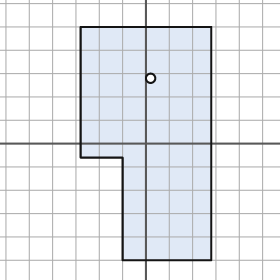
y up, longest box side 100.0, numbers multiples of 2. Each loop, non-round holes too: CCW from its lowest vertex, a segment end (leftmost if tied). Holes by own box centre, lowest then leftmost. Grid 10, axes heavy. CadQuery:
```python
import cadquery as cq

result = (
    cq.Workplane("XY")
    .moveTo(-10.0, -50.0)
    .lineTo(28.0, -50.0)
    .lineTo(28.0, 50.0)
    .lineTo(-28.0, 50.0)
    .lineTo(-28.0, -6.0)
    .lineTo(-10.0, -6.0)
    .close()
    .moveTo(2.0, 28.0)
    .circle(2.0)
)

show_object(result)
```